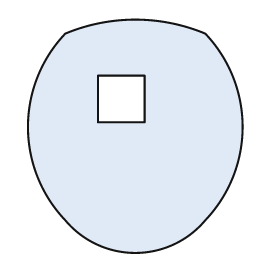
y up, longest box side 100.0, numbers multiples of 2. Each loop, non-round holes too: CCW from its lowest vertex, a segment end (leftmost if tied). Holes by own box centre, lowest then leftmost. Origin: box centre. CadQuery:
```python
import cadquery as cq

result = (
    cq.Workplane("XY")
    .moveTo(-30.0, -36.0)
    .threePointArc((0.0, -50.0), (30.0, -36.0))
    .threePointArc((46.0, 4.0), (30.0, 44.0))
    .threePointArc((0.0, 50.0), (-30.0, 44.0))
    .threePointArc((-46.0, 4.0), (-30.0, -36.0))
    .close()
    .moveTo(-16.0, 6.0)
    .lineTo(4.0, 6.0)
    .lineTo(4.0, 26.0)
    .lineTo(-16.0, 26.0)
    .close()
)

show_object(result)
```